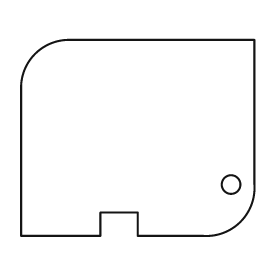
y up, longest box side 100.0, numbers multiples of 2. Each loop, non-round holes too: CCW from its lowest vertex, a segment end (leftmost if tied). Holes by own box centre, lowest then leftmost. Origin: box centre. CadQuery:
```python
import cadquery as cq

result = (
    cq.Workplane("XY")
    .moveTo(-50.0, -42.0)
    .lineTo(-16.0, -42.0)
    .lineTo(-16.0, -32.0)
    .lineTo(0.0, -32.0)
    .lineTo(0.0, -42.0)
    .lineTo(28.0, -42.0)
    .threePointArc((44.0, -36.0), (50.0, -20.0))
    .lineTo(50.0, 42.0)
    .lineTo(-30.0, 42.0)
    .threePointArc((-44.0, 36.0), (-50.0, 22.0))
    .close()
    .moveTo(40.0, -20.0)
    .circle(4.0)
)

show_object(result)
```